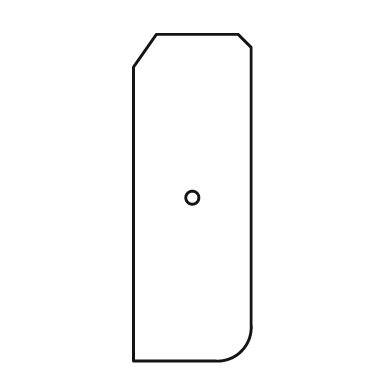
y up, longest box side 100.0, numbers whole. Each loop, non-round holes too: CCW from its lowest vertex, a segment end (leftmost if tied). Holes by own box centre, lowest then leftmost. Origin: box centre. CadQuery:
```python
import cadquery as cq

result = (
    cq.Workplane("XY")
    .moveTo(-18.0, -50.0)
    .lineTo(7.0, -50.0)
    .threePointArc((15.0, -47.0), (18.0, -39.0))
    .lineTo(18.0, 46.0)
    .lineTo(14.0, 50.0)
    .lineTo(-11.0, 50.0)
    .lineTo(-18.0, 40.0)
    .close()
    .moveTo(0.0, 0.0)
    .circle(2.0)
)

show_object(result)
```